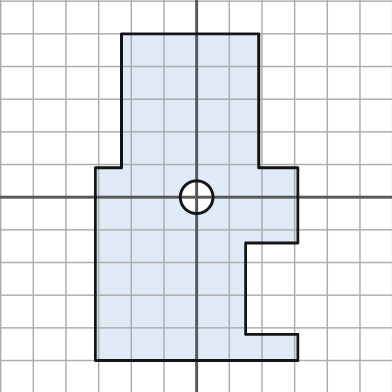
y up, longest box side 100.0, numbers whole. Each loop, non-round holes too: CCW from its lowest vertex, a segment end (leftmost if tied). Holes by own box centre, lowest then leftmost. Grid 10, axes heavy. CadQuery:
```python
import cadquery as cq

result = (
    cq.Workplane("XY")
    .moveTo(-31.0, -50.0)
    .lineTo(31.0, -50.0)
    .lineTo(31.0, -42.0)
    .lineTo(15.0, -42.0)
    .lineTo(15.0, -14.0)
    .lineTo(31.0, -14.0)
    .lineTo(31.0, 9.0)
    .lineTo(19.0, 9.0)
    .lineTo(19.0, 50.0)
    .lineTo(-23.0, 50.0)
    .lineTo(-23.0, 9.0)
    .lineTo(-31.0, 9.0)
    .close()
    .moveTo(0.0, 0.0)
    .circle(5.0)
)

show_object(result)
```